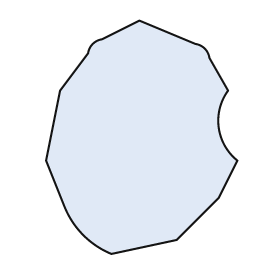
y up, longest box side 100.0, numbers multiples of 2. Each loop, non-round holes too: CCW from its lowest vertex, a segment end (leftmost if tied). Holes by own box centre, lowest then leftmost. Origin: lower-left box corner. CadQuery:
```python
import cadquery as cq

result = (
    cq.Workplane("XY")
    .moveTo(28.0, 0.0)
    .lineTo(56.0, 6.0)
    .lineTo(74.0, 24.0)
    .lineTo(82.0, 40.0)
    .threePointArc((74.0, 54.0), (78.0, 70.0))
    .lineTo(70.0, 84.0)
    .threePointArc((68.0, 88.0), (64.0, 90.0))
    .lineTo(40.0, 100.0)
    .lineTo(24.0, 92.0)
    .threePointArc((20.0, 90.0), (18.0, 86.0))
    .lineTo(6.0, 70.0)
    .lineTo(0.0, 40.0)
    .lineTo(8.0, 20.0)
    .threePointArc((16.0, 8.0), (28.0, 0.0))
    .close()
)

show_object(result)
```